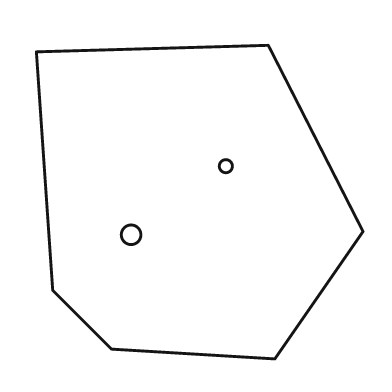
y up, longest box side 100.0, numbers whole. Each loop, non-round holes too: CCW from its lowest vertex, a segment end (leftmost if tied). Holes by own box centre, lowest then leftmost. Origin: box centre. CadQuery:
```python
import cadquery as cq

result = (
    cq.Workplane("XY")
    .moveTo(23.0, -48.0)
    .lineTo(50.0, -9.0)
    .lineTo(21.0, 48.0)
    .lineTo(-50.0, 46.0)
    .lineTo(-45.0, -27.0)
    .lineTo(-27.0, -45.0)
    .close()
    .moveTo(-21.0, -10.0)
    .circle(3.0)
    .moveTo(8.0, 11.0)
    .circle(2.0)
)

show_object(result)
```